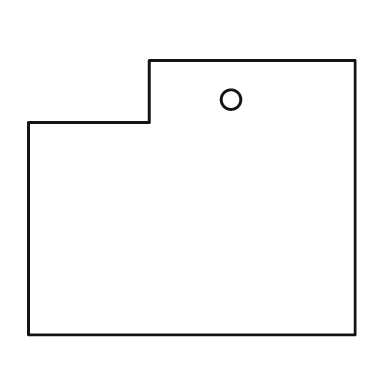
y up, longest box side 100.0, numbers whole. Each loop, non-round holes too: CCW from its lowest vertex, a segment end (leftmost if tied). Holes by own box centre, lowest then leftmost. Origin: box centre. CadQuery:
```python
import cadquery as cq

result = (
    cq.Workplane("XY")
    .moveTo(-50.0, -42.0)
    .lineTo(50.0, -42.0)
    .lineTo(50.0, 42.0)
    .lineTo(-13.0, 42.0)
    .lineTo(-13.0, 23.0)
    .lineTo(-50.0, 23.0)
    .close()
    .moveTo(12.0, 30.0)
    .circle(3.0)
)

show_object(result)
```